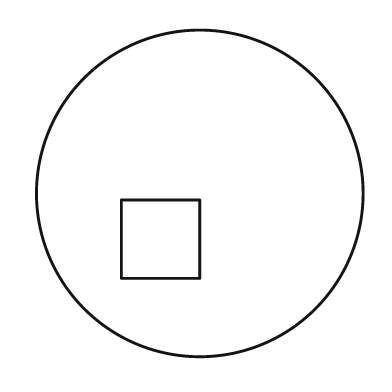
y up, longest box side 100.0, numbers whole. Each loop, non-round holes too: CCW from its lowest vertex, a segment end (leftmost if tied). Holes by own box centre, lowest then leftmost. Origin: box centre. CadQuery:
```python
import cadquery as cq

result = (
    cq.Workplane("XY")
    .moveTo(0.0, 0.0)
    .circle(50.0)
    .moveTo(-24.0, -26.0)
    .lineTo(0.0, -26.0)
    .lineTo(0.0, -2.0)
    .lineTo(-24.0, -2.0)
    .close()
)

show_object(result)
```